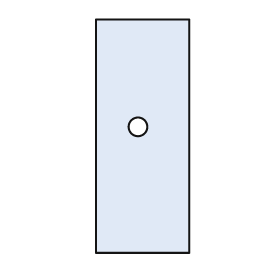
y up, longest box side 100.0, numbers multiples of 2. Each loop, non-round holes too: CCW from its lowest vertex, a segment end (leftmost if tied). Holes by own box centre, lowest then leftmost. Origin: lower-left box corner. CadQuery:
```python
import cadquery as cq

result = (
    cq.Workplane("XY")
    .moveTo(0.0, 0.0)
    .lineTo(40.0, 0.0)
    .lineTo(40.0, 100.0)
    .lineTo(0.0, 100.0)
    .close()
    .moveTo(18.0, 54.0)
    .circle(4.0)
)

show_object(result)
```